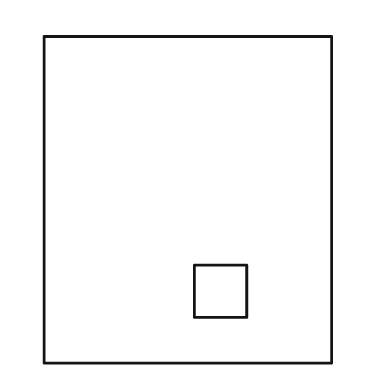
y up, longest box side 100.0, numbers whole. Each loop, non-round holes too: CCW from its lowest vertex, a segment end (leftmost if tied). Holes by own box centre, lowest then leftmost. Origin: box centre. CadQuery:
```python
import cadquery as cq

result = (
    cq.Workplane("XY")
    .moveTo(-44.0, -50.0)
    .lineTo(44.0, -50.0)
    .lineTo(44.0, 50.0)
    .lineTo(-44.0, 50.0)
    .close()
    .moveTo(2.0, -36.0)
    .lineTo(18.0, -36.0)
    .lineTo(18.0, -20.0)
    .lineTo(2.0, -20.0)
    .close()
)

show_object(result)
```